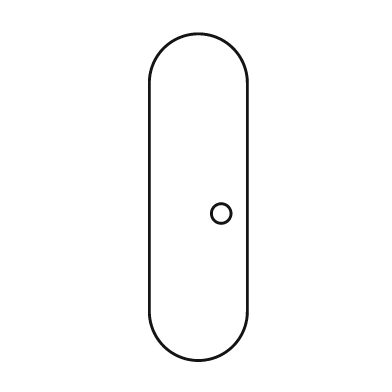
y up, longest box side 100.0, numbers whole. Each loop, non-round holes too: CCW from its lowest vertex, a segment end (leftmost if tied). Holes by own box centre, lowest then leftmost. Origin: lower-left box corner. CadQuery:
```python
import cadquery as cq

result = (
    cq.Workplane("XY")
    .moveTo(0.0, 15.0)
    .threePointArc((15.0, 0.0), (30.0, 15.0))
    .lineTo(30.0, 85.0)
    .threePointArc((15.0, 100.0), (0.0, 85.0))
    .close()
    .moveTo(22.0, 45.0)
    .circle(3.0)
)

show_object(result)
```